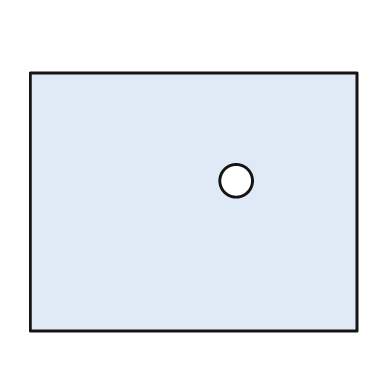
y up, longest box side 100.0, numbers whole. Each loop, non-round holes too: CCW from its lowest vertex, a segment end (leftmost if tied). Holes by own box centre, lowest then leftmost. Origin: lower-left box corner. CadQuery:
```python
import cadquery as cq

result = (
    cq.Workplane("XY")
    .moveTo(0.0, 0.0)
    .lineTo(100.0, 0.0)
    .lineTo(100.0, 79.0)
    .lineTo(0.0, 79.0)
    .close()
    .moveTo(63.0, 46.0)
    .circle(5.0)
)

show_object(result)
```